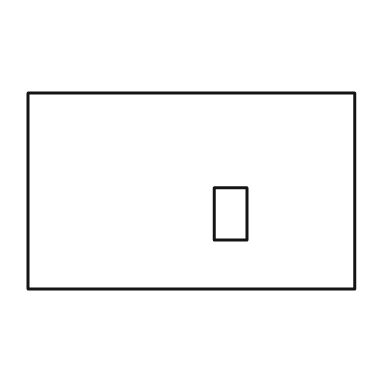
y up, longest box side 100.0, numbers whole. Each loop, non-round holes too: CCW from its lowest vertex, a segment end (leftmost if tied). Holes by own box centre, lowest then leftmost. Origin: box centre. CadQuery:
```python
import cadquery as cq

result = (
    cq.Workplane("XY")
    .moveTo(-50.0, -30.0)
    .lineTo(50.0, -30.0)
    .lineTo(50.0, 30.0)
    .lineTo(-50.0, 30.0)
    .close()
    .moveTo(7.0, -15.0)
    .lineTo(17.0, -15.0)
    .lineTo(17.0, 1.0)
    .lineTo(7.0, 1.0)
    .close()
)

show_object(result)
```